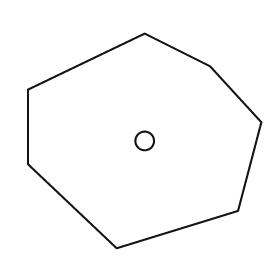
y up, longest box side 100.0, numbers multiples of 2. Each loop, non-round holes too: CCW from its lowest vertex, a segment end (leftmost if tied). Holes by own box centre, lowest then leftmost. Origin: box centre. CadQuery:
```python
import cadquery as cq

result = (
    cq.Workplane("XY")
    .moveTo(-12.0, -46.0)
    .lineTo(40.0, -30.0)
    .lineTo(50.0, 8.0)
    .lineTo(28.0, 32.0)
    .lineTo(0.0, 46.0)
    .lineTo(-50.0, 22.0)
    .lineTo(-50.0, -10.0)
    .close()
    .moveTo(0.0, 0.0)
    .circle(4.0)
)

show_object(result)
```